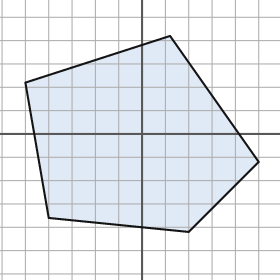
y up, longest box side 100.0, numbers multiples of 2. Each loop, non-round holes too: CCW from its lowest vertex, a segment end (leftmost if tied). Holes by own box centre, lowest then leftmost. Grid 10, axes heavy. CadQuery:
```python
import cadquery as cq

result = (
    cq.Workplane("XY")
    .moveTo(20.0, -42.0)
    .lineTo(50.0, -12.0)
    .lineTo(12.0, 42.0)
    .lineTo(-50.0, 22.0)
    .lineTo(-40.0, -36.0)
    .close()
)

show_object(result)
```